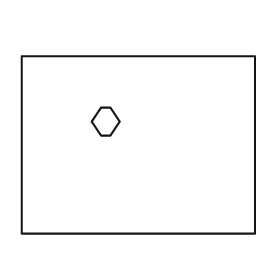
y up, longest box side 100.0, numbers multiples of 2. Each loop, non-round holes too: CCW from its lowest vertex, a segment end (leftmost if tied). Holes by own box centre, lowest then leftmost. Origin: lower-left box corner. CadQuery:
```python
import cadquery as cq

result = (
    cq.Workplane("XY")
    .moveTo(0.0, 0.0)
    .lineTo(100.0, 0.0)
    .lineTo(100.0, 76.0)
    .lineTo(0.0, 76.0)
    .close()
    .moveTo(34.0, 42.0)
    .lineTo(38.0, 42.0)
    .lineTo(42.0, 48.0)
    .lineTo(38.0, 54.0)
    .lineTo(34.0, 54.0)
    .lineTo(30.0, 48.0)
    .close()
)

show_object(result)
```